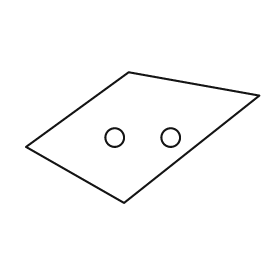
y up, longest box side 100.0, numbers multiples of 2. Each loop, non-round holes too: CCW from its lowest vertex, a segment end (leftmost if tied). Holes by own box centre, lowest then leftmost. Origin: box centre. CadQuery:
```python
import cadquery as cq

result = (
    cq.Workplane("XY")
    .moveTo(-8.0, -28.0)
    .lineTo(50.0, 18.0)
    .lineTo(-6.0, 28.0)
    .lineTo(-50.0, -4.0)
    .close()
    .moveTo(-12.0, 0.0)
    .circle(4.0)
    .moveTo(12.0, 0.0)
    .circle(4.0)
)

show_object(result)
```